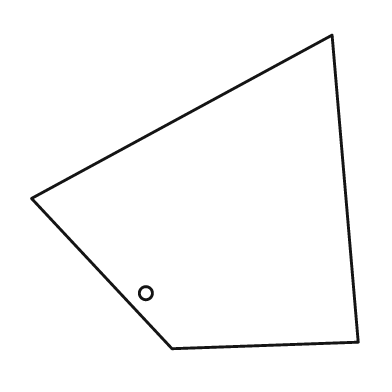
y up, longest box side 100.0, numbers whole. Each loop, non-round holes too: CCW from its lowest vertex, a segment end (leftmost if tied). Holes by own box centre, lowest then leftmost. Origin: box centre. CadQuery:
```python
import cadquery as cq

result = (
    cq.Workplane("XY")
    .moveTo(-7.0, -48.0)
    .lineTo(50.0, -46.0)
    .lineTo(42.0, 48.0)
    .lineTo(-50.0, -2.0)
    .close()
    .moveTo(-15.0, -31.0)
    .circle(2.0)
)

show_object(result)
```